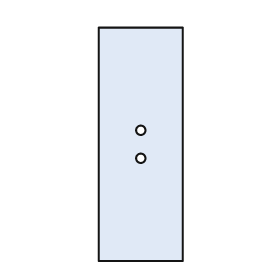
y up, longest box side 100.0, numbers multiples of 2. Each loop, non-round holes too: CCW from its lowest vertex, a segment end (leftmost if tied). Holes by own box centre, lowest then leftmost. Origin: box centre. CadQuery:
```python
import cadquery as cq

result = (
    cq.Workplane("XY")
    .moveTo(-18.0, -50.0)
    .lineTo(18.0, -50.0)
    .lineTo(18.0, 50.0)
    .lineTo(-18.0, 50.0)
    .close()
    .moveTo(0.0, -6.0)
    .circle(2.0)
    .moveTo(0.0, 6.0)
    .circle(2.0)
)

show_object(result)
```